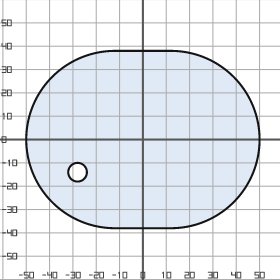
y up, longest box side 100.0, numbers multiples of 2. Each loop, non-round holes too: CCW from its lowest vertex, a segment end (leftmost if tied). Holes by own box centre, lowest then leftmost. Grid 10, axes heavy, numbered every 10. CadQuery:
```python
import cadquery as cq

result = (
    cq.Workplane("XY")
    .moveTo(-12.0, -38.0)
    .lineTo(12.0, -38.0)
    .threePointArc((50.0, 0.0), (12.0, 38.0))
    .lineTo(-12.0, 38.0)
    .threePointArc((-50.0, 0.0), (-12.0, -38.0))
    .close()
    .moveTo(-28.0, -14.0)
    .circle(4.0)
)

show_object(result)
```